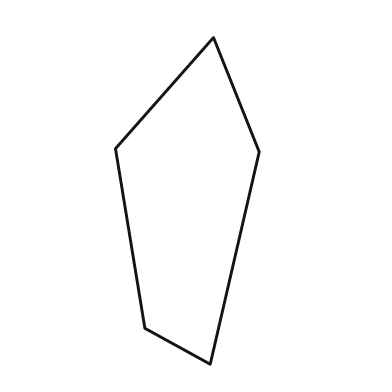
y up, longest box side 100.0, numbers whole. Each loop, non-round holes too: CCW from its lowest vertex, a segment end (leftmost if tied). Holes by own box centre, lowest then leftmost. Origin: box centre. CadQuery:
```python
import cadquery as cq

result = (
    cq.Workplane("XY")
    .moveTo(7.0, -50.0)
    .lineTo(22.0, 15.0)
    .lineTo(8.0, 50.0)
    .lineTo(-22.0, 16.0)
    .lineTo(-13.0, -39.0)
    .close()
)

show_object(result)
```